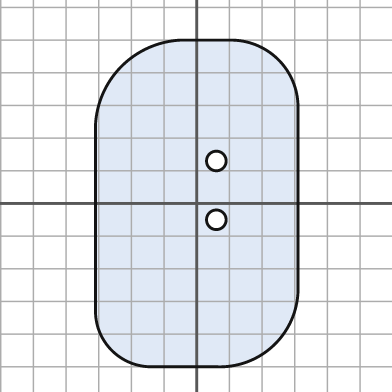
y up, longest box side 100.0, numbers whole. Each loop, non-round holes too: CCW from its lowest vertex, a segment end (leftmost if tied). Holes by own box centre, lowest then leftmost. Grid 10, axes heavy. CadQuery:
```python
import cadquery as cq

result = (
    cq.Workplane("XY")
    .moveTo(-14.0, -50.0)
    .lineTo(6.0, -50.0)
    .threePointArc((24.0, -43.0), (31.0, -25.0))
    .lineTo(31.0, 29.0)
    .threePointArc((25.0, 44.0), (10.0, 50.0))
    .lineTo(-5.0, 50.0)
    .threePointArc((-23.0, 42.0), (-31.0, 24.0))
    .lineTo(-31.0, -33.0)
    .threePointArc((-26.0, -45.0), (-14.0, -50.0))
    .close()
    .moveTo(6.0, -5.0)
    .circle(3.0)
    .moveTo(6.0, 13.0)
    .circle(3.0)
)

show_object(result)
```